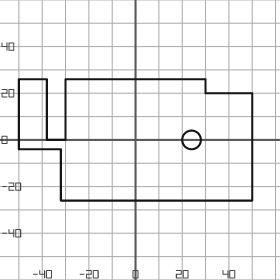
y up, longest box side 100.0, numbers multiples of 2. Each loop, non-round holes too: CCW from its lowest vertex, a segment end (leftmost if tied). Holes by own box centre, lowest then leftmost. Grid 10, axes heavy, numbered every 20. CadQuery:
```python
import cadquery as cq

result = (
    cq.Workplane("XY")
    .moveTo(-32.0, -26.0)
    .lineTo(50.0, -26.0)
    .lineTo(50.0, 20.0)
    .lineTo(30.0, 20.0)
    .lineTo(30.0, 26.0)
    .lineTo(-30.0, 26.0)
    .lineTo(-30.0, 0.0)
    .lineTo(-38.0, 0.0)
    .lineTo(-38.0, 26.0)
    .lineTo(-50.0, 26.0)
    .lineTo(-50.0, -4.0)
    .lineTo(-32.0, -4.0)
    .close()
    .moveTo(24.0, 0.0)
    .circle(4.0)
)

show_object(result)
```